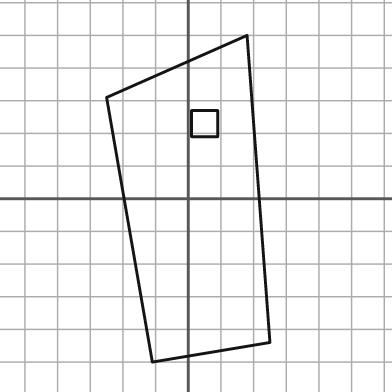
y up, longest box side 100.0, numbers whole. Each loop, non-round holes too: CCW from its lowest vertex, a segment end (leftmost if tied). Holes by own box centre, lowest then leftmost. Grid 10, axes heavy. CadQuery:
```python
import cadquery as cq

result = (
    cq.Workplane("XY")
    .moveTo(-11.0, -50.0)
    .lineTo(25.0, -44.0)
    .lineTo(18.0, 50.0)
    .lineTo(-25.0, 31.0)
    .close()
    .moveTo(1.0, 19.0)
    .lineTo(9.0, 19.0)
    .lineTo(9.0, 27.0)
    .lineTo(1.0, 27.0)
    .close()
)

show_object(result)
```